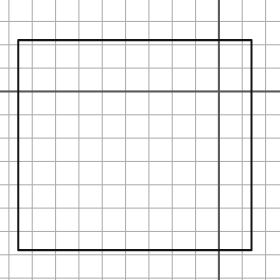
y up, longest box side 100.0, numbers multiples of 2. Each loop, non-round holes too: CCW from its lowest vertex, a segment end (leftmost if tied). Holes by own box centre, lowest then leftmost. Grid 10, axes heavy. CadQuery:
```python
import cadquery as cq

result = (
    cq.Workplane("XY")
    .moveTo(-86.0, -68.0)
    .lineTo(14.0, -68.0)
    .lineTo(14.0, 22.0)
    .lineTo(-86.0, 22.0)
    .close()
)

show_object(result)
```